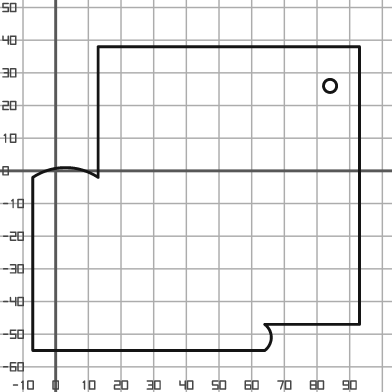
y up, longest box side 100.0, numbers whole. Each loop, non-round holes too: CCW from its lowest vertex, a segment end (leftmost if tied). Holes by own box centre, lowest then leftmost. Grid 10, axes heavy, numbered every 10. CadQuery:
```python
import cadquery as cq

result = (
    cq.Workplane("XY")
    .moveTo(-7.0, -55.0)
    .lineTo(64.0, -55.0)
    .threePointArc((66.0, -51.0), (64.0, -47.0))
    .lineTo(93.0, -47.0)
    .lineTo(93.0, 38.0)
    .lineTo(13.0, 38.0)
    .lineTo(13.0, -2.0)
    .threePointArc((3.0, 1.0), (-7.0, -2.0))
    .close()
    .moveTo(84.0, 26.0)
    .circle(2.0)
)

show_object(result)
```